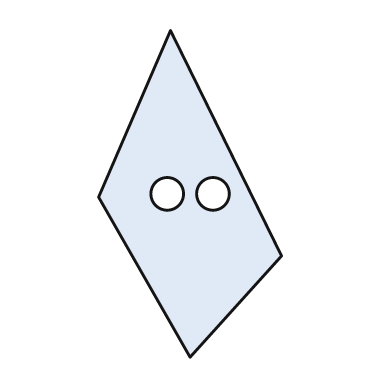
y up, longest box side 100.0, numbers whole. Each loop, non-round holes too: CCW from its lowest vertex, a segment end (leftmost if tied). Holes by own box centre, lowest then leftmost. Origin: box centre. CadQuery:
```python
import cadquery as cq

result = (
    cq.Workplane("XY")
    .moveTo(0.0, -50.0)
    .lineTo(28.0, -19.0)
    .lineTo(-6.0, 50.0)
    .lineTo(-28.0, -1.0)
    .close()
    .moveTo(-7.0, 0.0)
    .circle(5.0)
    .moveTo(7.0, 0.0)
    .circle(5.0)
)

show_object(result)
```